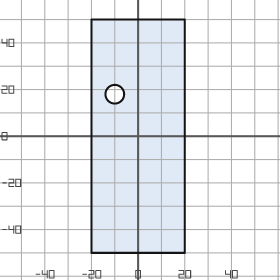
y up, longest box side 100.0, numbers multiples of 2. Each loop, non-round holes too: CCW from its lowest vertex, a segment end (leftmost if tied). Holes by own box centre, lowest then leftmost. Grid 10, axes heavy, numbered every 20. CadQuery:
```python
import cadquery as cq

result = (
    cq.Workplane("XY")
    .moveTo(-20.0, -50.0)
    .lineTo(20.0, -50.0)
    .lineTo(20.0, 50.0)
    .lineTo(-20.0, 50.0)
    .close()
    .moveTo(-10.0, 18.0)
    .circle(4.0)
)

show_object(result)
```